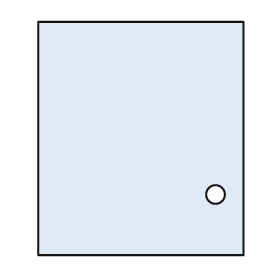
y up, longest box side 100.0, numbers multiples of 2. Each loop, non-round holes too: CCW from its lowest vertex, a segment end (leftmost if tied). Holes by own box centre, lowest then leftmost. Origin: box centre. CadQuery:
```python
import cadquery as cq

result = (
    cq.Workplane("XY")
    .moveTo(-44.0, -50.0)
    .lineTo(44.0, -50.0)
    .lineTo(44.0, 50.0)
    .lineTo(-44.0, 50.0)
    .close()
    .moveTo(32.0, -24.0)
    .circle(4.0)
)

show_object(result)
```